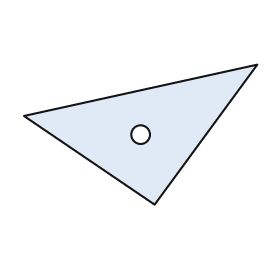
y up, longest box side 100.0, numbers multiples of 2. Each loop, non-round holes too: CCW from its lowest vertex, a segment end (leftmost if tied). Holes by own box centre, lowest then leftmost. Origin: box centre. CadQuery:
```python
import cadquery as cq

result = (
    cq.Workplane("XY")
    .moveTo(6.0, -30.0)
    .lineTo(50.0, 30.0)
    .lineTo(-50.0, 8.0)
    .close()
    .moveTo(0.0, 0.0)
    .circle(4.0)
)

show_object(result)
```